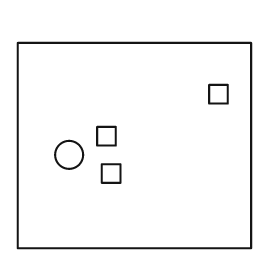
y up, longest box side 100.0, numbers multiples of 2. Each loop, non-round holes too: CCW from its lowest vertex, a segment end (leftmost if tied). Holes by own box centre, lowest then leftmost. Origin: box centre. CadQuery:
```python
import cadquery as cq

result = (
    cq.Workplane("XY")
    .moveTo(-50.0, -44.0)
    .lineTo(50.0, -44.0)
    .lineTo(50.0, 44.0)
    .lineTo(-50.0, 44.0)
    .close()
    .moveTo(-14.0, -16.0)
    .lineTo(-6.0, -16.0)
    .lineTo(-6.0, -8.0)
    .lineTo(-14.0, -8.0)
    .close()
    .moveTo(-28.0, -4.0)
    .circle(6.0)
    .moveTo(-16.0, 0.0)
    .lineTo(-8.0, 0.0)
    .lineTo(-8.0, 8.0)
    .lineTo(-16.0, 8.0)
    .close()
    .moveTo(32.0, 18.0)
    .lineTo(40.0, 18.0)
    .lineTo(40.0, 26.0)
    .lineTo(32.0, 26.0)
    .close()
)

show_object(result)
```